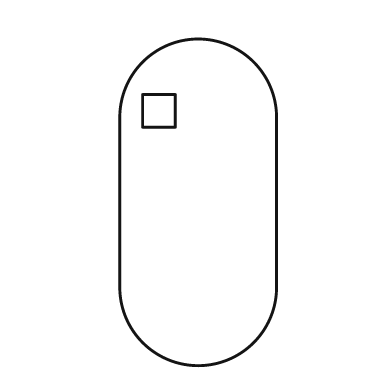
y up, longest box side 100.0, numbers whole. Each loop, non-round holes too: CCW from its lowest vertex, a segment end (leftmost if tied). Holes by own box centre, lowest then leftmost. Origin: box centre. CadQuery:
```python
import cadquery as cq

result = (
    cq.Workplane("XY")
    .moveTo(-24.0, -26.0)
    .threePointArc((0.0, -50.0), (24.0, -26.0))
    .lineTo(24.0, 26.0)
    .threePointArc((0.0, 50.0), (-24.0, 26.0))
    .close()
    .moveTo(-17.0, 23.0)
    .lineTo(-7.0, 23.0)
    .lineTo(-7.0, 33.0)
    .lineTo(-17.0, 33.0)
    .close()
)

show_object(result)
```